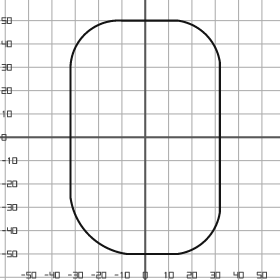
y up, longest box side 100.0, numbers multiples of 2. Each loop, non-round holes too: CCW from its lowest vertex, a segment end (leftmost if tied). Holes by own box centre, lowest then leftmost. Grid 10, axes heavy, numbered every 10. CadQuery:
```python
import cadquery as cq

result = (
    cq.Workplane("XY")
    .moveTo(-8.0, -50.0)
    .lineTo(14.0, -50.0)
    .threePointArc((26.0, -44.0), (32.0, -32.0))
    .lineTo(32.0, 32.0)
    .threePointArc((26.0, 44.0), (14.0, 50.0))
    .lineTo(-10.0, 50.0)
    .threePointArc((-26.0, 44.0), (-32.0, 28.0))
    .lineTo(-32.0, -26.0)
    .threePointArc((-24.0, -42.0), (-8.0, -50.0))
    .close()
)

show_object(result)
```